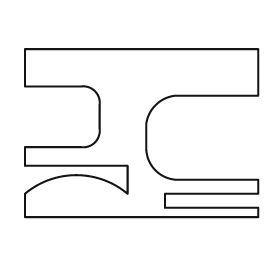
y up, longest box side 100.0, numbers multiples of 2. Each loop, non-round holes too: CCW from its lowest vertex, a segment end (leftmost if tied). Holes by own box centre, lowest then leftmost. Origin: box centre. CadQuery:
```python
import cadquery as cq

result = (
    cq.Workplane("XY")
    .moveTo(-50.0, -36.0)
    .lineTo(50.0, -36.0)
    .lineTo(50.0, -32.0)
    .lineTo(10.0, -32.0)
    .lineTo(10.0, -26.0)
    .lineTo(50.0, -26.0)
    .lineTo(50.0, -20.0)
    .lineTo(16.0, -20.0)
    .threePointArc((6.0, -16.0), (2.0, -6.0))
    .lineTo(2.0, 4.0)
    .threePointArc((6.0, 12.0), (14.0, 16.0))
    .lineTo(50.0, 16.0)
    .lineTo(50.0, 36.0)
    .lineTo(-50.0, 36.0)
    .lineTo(-50.0, 20.0)
    .lineTo(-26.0, 20.0)
    .threePointArc((-20.0, 18.0), (-18.0, 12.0))
    .lineTo(-18.0, 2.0)
    .threePointArc((-20.0, -4.0), (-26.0, -6.0))
    .lineTo(-50.0, -6.0)
    .lineTo(-50.0, -14.0)
    .lineTo(-6.0, -14.0)
    .lineTo(-6.0, -26.0)
    .threePointArc((-28.0, -18.0), (-50.0, -26.0))
    .close()
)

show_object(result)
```